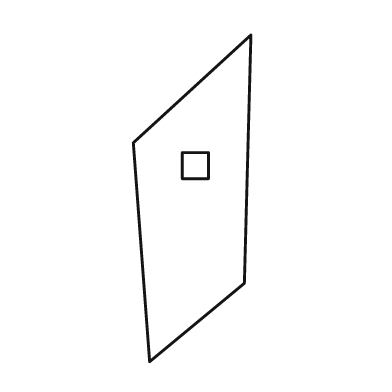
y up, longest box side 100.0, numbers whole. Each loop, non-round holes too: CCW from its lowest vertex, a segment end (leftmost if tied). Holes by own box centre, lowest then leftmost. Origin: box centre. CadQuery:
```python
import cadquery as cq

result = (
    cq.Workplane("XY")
    .moveTo(-13.0, -50.0)
    .lineTo(16.0, -26.0)
    .lineTo(18.0, 50.0)
    .lineTo(-18.0, 17.0)
    .close()
    .moveTo(-3.0, 6.0)
    .lineTo(5.0, 6.0)
    .lineTo(5.0, 14.0)
    .lineTo(-3.0, 14.0)
    .close()
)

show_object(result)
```